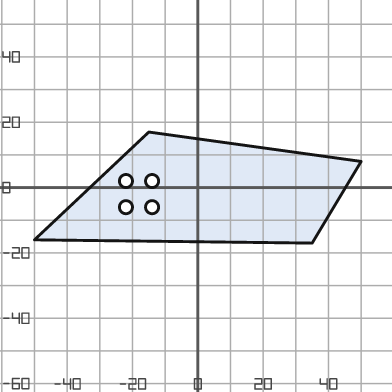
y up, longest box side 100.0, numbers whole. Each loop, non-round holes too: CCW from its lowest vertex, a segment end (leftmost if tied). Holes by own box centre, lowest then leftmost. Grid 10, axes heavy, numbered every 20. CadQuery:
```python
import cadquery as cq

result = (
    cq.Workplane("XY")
    .moveTo(35.0, -17.0)
    .lineTo(50.0, 8.0)
    .lineTo(-15.0, 17.0)
    .lineTo(-50.0, -16.0)
    .close()
    .moveTo(-22.0, -6.0)
    .circle(2.0)
    .moveTo(-14.0, -6.0)
    .circle(2.0)
    .moveTo(-22.0, 2.0)
    .circle(2.0)
    .moveTo(-14.0, 2.0)
    .circle(2.0)
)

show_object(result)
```